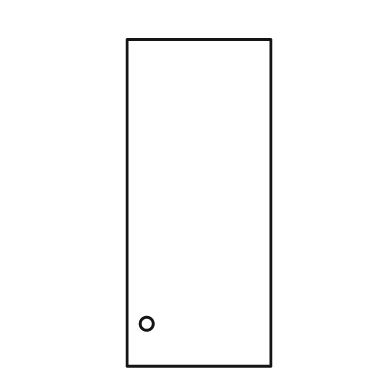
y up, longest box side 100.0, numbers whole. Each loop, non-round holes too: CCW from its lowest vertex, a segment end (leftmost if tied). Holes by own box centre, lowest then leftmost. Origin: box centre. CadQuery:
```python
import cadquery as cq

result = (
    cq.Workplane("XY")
    .moveTo(-22.0, -50.0)
    .lineTo(22.0, -50.0)
    .lineTo(22.0, 50.0)
    .lineTo(-22.0, 50.0)
    .close()
    .moveTo(-16.0, -37.0)
    .circle(2.0)
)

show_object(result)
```